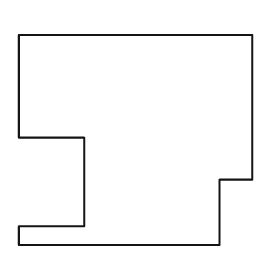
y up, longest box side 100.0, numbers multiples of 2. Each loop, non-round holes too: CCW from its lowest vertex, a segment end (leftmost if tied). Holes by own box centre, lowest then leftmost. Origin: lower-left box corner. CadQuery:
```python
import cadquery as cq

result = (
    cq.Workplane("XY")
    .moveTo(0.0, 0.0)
    .lineTo(86.0, 0.0)
    .lineTo(86.0, 28.0)
    .lineTo(100.0, 28.0)
    .lineTo(100.0, 90.0)
    .lineTo(0.0, 90.0)
    .lineTo(0.0, 46.0)
    .lineTo(28.0, 46.0)
    .lineTo(28.0, 8.0)
    .lineTo(0.0, 8.0)
    .close()
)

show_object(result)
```